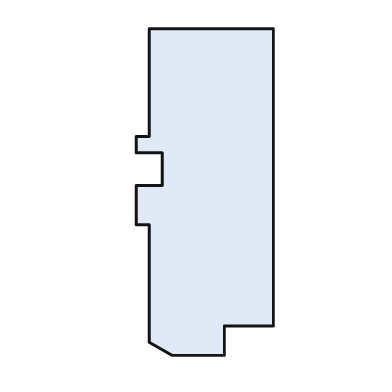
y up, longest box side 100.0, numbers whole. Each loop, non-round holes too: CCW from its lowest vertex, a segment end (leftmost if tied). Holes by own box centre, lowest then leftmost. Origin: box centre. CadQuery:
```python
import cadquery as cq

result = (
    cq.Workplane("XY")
    .moveTo(-10.0, -50.0)
    .lineTo(6.0, -50.0)
    .lineTo(6.0, -41.0)
    .lineTo(21.0, -41.0)
    .lineTo(21.0, 50.0)
    .lineTo(-17.0, 50.0)
    .lineTo(-17.0, 17.0)
    .lineTo(-21.0, 17.0)
    .lineTo(-21.0, 12.0)
    .lineTo(-13.0, 12.0)
    .lineTo(-13.0, 2.0)
    .lineTo(-21.0, 2.0)
    .lineTo(-21.0, -10.0)
    .lineTo(-17.0, -10.0)
    .lineTo(-17.0, -46.0)
    .close()
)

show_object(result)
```